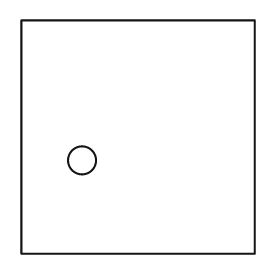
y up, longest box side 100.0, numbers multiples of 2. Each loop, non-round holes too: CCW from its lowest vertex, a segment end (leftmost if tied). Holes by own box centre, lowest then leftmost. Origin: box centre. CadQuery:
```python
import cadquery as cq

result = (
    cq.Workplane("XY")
    .moveTo(-50.0, -50.0)
    .lineTo(50.0, -50.0)
    .lineTo(50.0, 50.0)
    .lineTo(-50.0, 50.0)
    .close()
    .moveTo(-24.0, -10.0)
    .circle(6.0)
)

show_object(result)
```